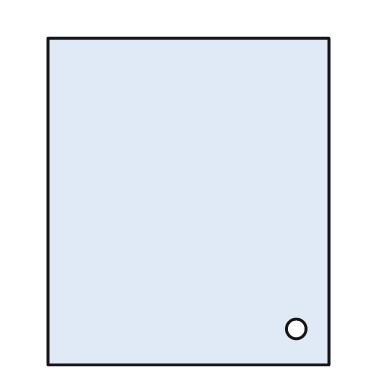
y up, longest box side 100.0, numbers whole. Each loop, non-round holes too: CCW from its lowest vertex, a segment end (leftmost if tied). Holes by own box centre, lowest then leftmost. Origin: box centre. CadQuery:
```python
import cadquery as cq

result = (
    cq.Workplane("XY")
    .moveTo(-43.0, -50.0)
    .lineTo(43.0, -50.0)
    .lineTo(43.0, 50.0)
    .lineTo(-43.0, 50.0)
    .close()
    .moveTo(33.0, -39.0)
    .circle(3.0)
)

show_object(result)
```